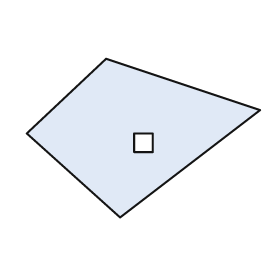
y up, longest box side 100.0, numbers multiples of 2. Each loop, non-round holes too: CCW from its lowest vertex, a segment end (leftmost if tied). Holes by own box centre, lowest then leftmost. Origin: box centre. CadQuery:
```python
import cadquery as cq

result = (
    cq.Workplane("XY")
    .moveTo(-10.0, -34.0)
    .lineTo(50.0, 12.0)
    .lineTo(-16.0, 34.0)
    .lineTo(-50.0, 2.0)
    .close()
    .moveTo(-4.0, -6.0)
    .lineTo(4.0, -6.0)
    .lineTo(4.0, 2.0)
    .lineTo(-4.0, 2.0)
    .close()
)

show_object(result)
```